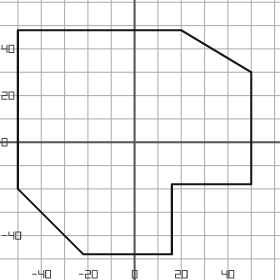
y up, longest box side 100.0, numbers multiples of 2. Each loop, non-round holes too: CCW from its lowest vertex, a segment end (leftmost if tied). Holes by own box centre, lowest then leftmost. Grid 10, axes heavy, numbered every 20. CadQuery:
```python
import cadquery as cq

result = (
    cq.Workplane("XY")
    .moveTo(-22.0, -48.0)
    .lineTo(16.0, -48.0)
    .lineTo(16.0, -18.0)
    .lineTo(50.0, -18.0)
    .lineTo(50.0, 30.0)
    .lineTo(20.0, 48.0)
    .lineTo(-50.0, 48.0)
    .lineTo(-50.0, -20.0)
    .close()
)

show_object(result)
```